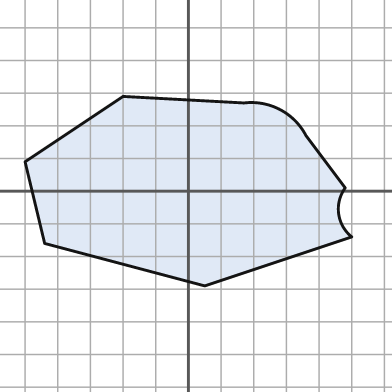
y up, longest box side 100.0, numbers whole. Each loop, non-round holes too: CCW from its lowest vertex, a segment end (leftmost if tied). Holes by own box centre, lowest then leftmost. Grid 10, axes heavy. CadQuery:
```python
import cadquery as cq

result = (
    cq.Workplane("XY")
    .moveTo(5.0, -29.0)
    .lineTo(50.0, -14.0)
    .threePointArc((46.0, -7.0), (48.0, 1.0))
    .lineTo(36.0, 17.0)
    .threePointArc((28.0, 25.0), (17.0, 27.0))
    .lineTo(-20.0, 29.0)
    .lineTo(-50.0, 9.0)
    .lineTo(-44.0, -16.0)
    .close()
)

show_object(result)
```